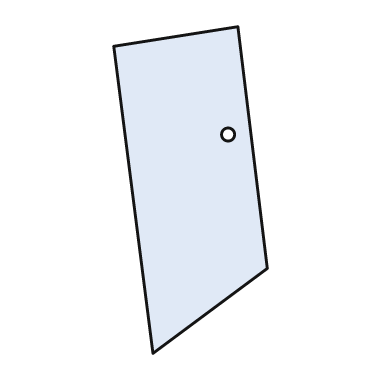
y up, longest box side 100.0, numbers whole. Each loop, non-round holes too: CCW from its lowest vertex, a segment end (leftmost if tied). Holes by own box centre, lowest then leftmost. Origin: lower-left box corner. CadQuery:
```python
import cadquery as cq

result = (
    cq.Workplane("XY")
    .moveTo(12.0, 0.0)
    .lineTo(47.0, 26.0)
    .lineTo(38.0, 100.0)
    .lineTo(0.0, 94.0)
    .close()
    .moveTo(35.0, 67.0)
    .circle(2.0)
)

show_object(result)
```